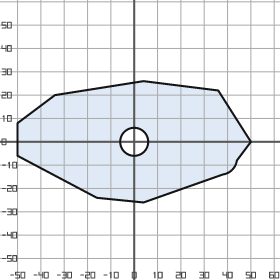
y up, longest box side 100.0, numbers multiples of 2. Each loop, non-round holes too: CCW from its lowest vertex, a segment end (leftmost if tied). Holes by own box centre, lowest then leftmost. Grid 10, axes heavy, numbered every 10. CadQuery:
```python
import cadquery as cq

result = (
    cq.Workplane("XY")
    .moveTo(4.0, -26.0)
    .lineTo(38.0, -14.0)
    .threePointArc((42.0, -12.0), (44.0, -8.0))
    .lineTo(50.0, 0.0)
    .lineTo(36.0, 22.0)
    .lineTo(4.0, 26.0)
    .lineTo(-34.0, 20.0)
    .lineTo(-50.0, 8.0)
    .lineTo(-50.0, -6.0)
    .lineTo(-16.0, -24.0)
    .close()
    .moveTo(0.0, 0.0)
    .circle(6.0)
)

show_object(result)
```